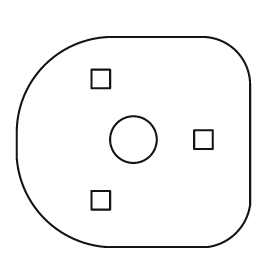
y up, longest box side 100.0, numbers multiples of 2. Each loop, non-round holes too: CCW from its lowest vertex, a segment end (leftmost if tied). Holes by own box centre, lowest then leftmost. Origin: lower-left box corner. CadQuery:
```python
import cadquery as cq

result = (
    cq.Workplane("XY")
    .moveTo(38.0, 0.0)
    .lineTo(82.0, 0.0)
    .threePointArc((94.0, 6.0), (100.0, 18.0))
    .lineTo(100.0, 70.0)
    .threePointArc((94.0, 84.0), (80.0, 90.0))
    .lineTo(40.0, 90.0)
    .threePointArc((12.0, 78.0), (0.0, 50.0))
    .lineTo(0.0, 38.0)
    .threePointArc((12.0, 12.0), (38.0, 0.0))
    .close()
    .moveTo(32.0, 16.0)
    .lineTo(40.0, 16.0)
    .lineTo(40.0, 24.0)
    .lineTo(32.0, 24.0)
    .close()
    .moveTo(50.0, 46.0)
    .circle(10.0)
    .moveTo(76.0, 42.0)
    .lineTo(84.0, 42.0)
    .lineTo(84.0, 50.0)
    .lineTo(76.0, 50.0)
    .close()
    .moveTo(32.0, 68.0)
    .lineTo(40.0, 68.0)
    .lineTo(40.0, 76.0)
    .lineTo(32.0, 76.0)
    .close()
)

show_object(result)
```